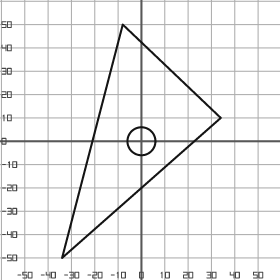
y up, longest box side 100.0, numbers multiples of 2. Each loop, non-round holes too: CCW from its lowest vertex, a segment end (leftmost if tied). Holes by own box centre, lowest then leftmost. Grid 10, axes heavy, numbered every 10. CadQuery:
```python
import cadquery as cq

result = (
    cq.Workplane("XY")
    .moveTo(-34.0, -50.0)
    .lineTo(34.0, 10.0)
    .lineTo(-8.0, 50.0)
    .close()
    .moveTo(0.0, 0.0)
    .circle(6.0)
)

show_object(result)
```